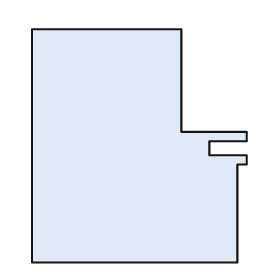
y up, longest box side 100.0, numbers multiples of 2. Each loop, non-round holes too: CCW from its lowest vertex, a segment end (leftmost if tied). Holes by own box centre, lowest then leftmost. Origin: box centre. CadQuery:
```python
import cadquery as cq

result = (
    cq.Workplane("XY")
    .moveTo(-46.0, -50.0)
    .lineTo(42.0, -50.0)
    .lineTo(42.0, -8.0)
    .lineTo(46.0, -8.0)
    .lineTo(46.0, -4.0)
    .lineTo(30.0, -4.0)
    .lineTo(30.0, 2.0)
    .lineTo(46.0, 2.0)
    .lineTo(46.0, 6.0)
    .lineTo(18.0, 6.0)
    .lineTo(18.0, 50.0)
    .lineTo(-46.0, 50.0)
    .close()
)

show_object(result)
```